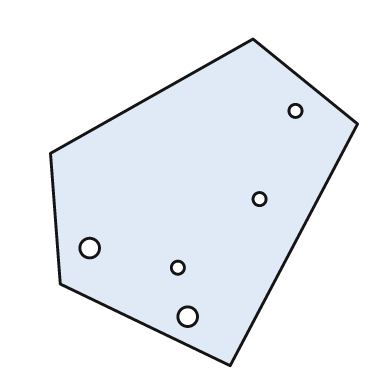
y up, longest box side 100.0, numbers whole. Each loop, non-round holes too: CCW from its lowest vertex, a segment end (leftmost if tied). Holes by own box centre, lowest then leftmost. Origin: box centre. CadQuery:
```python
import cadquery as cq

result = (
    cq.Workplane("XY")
    .moveTo(8.0, -50.0)
    .lineTo(47.0, 24.0)
    .lineTo(15.0, 50.0)
    .lineTo(-47.0, 15.0)
    .lineTo(-44.0, -25.0)
    .close()
    .moveTo(-5.0, -35.0)
    .circle(3.0)
    .moveTo(-8.0, -20.0)
    .circle(2.0)
    .moveTo(-35.0, -14.0)
    .circle(3.0)
    .moveTo(17.0, 1.0)
    .circle(2.0)
    .moveTo(28.0, 28.0)
    .circle(2.0)
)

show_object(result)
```